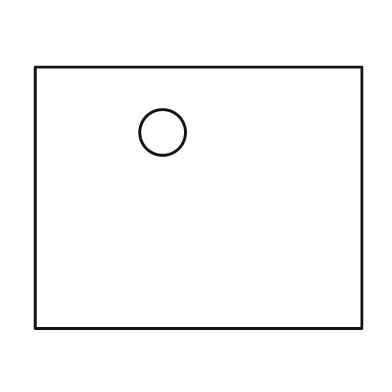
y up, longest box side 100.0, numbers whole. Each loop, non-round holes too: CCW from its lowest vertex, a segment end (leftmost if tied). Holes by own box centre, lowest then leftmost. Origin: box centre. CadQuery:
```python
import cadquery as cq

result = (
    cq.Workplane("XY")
    .moveTo(-50.0, -40.0)
    .lineTo(50.0, -40.0)
    .lineTo(50.0, 40.0)
    .lineTo(-50.0, 40.0)
    .close()
    .moveTo(-11.0, 20.0)
    .circle(7.0)
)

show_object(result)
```